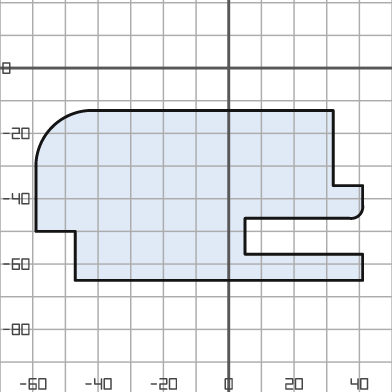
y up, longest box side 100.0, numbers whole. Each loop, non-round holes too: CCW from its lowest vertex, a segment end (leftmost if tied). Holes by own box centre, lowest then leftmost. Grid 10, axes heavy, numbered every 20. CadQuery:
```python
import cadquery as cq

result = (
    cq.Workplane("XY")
    .moveTo(-47.0, -65.0)
    .lineTo(41.0, -65.0)
    .lineTo(41.0, -57.0)
    .lineTo(5.0, -57.0)
    .lineTo(5.0, -46.0)
    .lineTo(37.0, -46.0)
    .threePointArc((40.0, -45.0), (41.0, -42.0))
    .lineTo(41.0, -36.0)
    .lineTo(32.0, -36.0)
    .lineTo(32.0, -13.0)
    .lineTo(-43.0, -13.0)
    .threePointArc((-54.0, -18.0), (-59.0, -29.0))
    .lineTo(-59.0, -50.0)
    .lineTo(-47.0, -50.0)
    .close()
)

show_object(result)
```